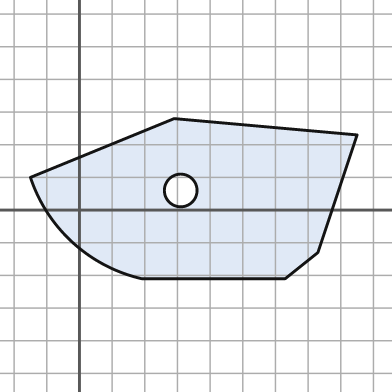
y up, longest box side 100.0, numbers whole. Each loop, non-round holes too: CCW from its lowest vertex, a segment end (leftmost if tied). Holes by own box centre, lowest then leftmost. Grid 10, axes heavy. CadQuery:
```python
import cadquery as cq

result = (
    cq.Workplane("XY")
    .moveTo(19.0, -21.0)
    .lineTo(63.0, -21.0)
    .lineTo(73.0, -13.0)
    .lineTo(85.0, 23.0)
    .lineTo(29.0, 28.0)
    .lineTo(-15.0, 10.0)
    .threePointArc((-2.0, -10.0), (19.0, -21.0))
    .close()
    .moveTo(31.0, 6.0)
    .circle(5.0)
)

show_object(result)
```